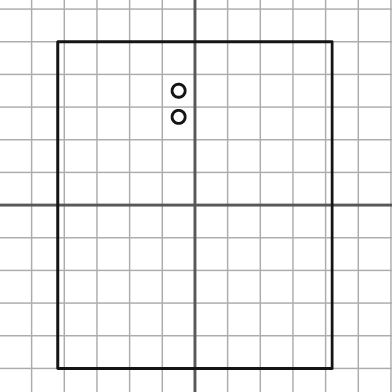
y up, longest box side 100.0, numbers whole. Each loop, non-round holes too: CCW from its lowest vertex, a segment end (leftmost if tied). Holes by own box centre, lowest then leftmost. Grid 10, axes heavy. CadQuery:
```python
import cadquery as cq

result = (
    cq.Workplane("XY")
    .moveTo(-42.0, -50.0)
    .lineTo(42.0, -50.0)
    .lineTo(42.0, 50.0)
    .lineTo(-42.0, 50.0)
    .close()
    .moveTo(-5.0, 27.0)
    .circle(2.0)
    .moveTo(-5.0, 35.0)
    .circle(2.0)
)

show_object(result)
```